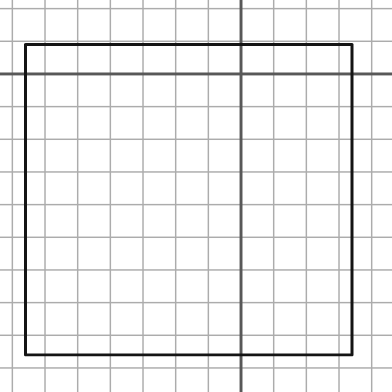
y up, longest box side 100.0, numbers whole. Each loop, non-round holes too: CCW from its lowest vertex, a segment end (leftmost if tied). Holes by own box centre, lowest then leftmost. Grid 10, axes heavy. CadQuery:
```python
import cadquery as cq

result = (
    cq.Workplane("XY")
    .moveTo(-66.0, -86.0)
    .lineTo(34.0, -86.0)
    .lineTo(34.0, 9.0)
    .lineTo(-66.0, 9.0)
    .close()
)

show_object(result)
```